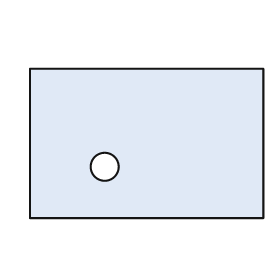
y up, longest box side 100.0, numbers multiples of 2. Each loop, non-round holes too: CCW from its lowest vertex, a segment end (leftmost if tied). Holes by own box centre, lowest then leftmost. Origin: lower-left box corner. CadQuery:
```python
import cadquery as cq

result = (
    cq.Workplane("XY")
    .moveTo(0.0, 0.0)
    .lineTo(100.0, 0.0)
    .lineTo(100.0, 64.0)
    .lineTo(0.0, 64.0)
    .close()
    .moveTo(32.0, 22.0)
    .circle(6.0)
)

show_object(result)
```